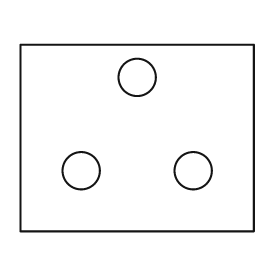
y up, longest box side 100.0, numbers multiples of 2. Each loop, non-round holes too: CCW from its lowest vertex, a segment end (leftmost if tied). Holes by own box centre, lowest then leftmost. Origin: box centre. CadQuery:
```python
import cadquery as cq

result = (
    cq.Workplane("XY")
    .moveTo(-50.0, -40.0)
    .lineTo(50.0, -40.0)
    .lineTo(50.0, 40.0)
    .lineTo(-50.0, 40.0)
    .close()
    .moveTo(-24.0, -14.0)
    .circle(8.0)
    .moveTo(24.0, -14.0)
    .circle(8.0)
    .moveTo(0.0, 26.0)
    .circle(8.0)
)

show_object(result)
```